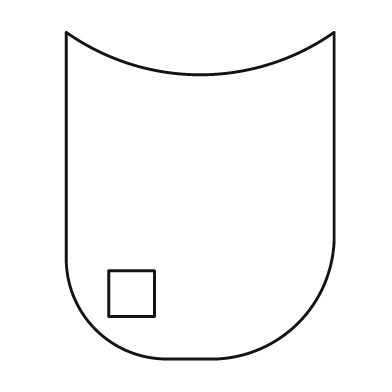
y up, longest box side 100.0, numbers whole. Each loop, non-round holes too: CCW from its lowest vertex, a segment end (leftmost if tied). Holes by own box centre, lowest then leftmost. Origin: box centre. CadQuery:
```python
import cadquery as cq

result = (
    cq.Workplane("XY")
    .moveTo(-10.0, -50.0)
    .lineTo(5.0, -50.0)
    .threePointArc((30.0, -39.0), (41.0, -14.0))
    .lineTo(41.0, 50.0)
    .threePointArc((0.0, 37.0), (-41.0, 50.0))
    .lineTo(-41.0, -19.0)
    .threePointArc((-32.0, -41.0), (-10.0, -50.0))
    .close()
    .moveTo(-28.0, -37.0)
    .lineTo(-14.0, -37.0)
    .lineTo(-14.0, -23.0)
    .lineTo(-28.0, -23.0)
    .close()
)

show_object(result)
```